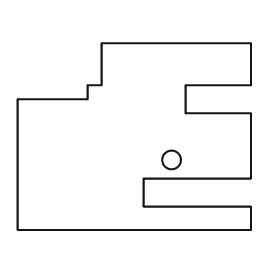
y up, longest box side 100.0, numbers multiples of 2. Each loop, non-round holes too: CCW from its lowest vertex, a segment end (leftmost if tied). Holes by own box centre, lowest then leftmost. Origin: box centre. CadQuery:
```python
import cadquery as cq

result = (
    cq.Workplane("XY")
    .moveTo(-50.0, -40.0)
    .lineTo(50.0, -40.0)
    .lineTo(50.0, -30.0)
    .lineTo(4.0, -30.0)
    .lineTo(4.0, -18.0)
    .lineTo(50.0, -18.0)
    .lineTo(50.0, 10.0)
    .lineTo(22.0, 10.0)
    .lineTo(22.0, 22.0)
    .lineTo(50.0, 22.0)
    .lineTo(50.0, 40.0)
    .lineTo(-14.0, 40.0)
    .lineTo(-14.0, 22.0)
    .lineTo(-20.0, 22.0)
    .lineTo(-20.0, 16.0)
    .lineTo(-50.0, 16.0)
    .close()
    .moveTo(16.0, -10.0)
    .circle(4.0)
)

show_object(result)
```